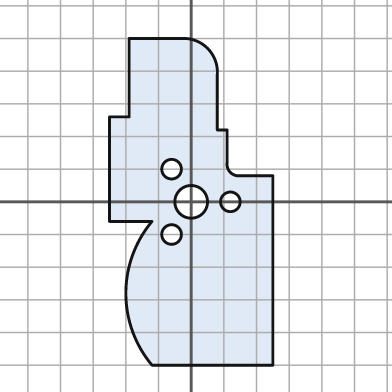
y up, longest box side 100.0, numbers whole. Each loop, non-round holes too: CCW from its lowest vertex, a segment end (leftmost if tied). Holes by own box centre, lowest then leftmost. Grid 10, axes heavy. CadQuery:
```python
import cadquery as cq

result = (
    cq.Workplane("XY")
    .moveTo(-12.0, -50.0)
    .lineTo(25.0, -50.0)
    .lineTo(25.0, 8.0)
    .lineTo(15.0, 8.0)
    .threePointArc((12.0, 9.0), (11.0, 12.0))
    .lineTo(11.0, 22.0)
    .lineTo(8.0, 22.0)
    .lineTo(8.0, 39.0)
    .threePointArc((5.0, 47.0), (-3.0, 50.0))
    .lineTo(-19.0, 50.0)
    .lineTo(-19.0, 26.0)
    .lineTo(-25.0, 26.0)
    .lineTo(-25.0, -6.0)
    .lineTo(-12.0, -6.0)
    .threePointArc((-20.0, -28.0), (-12.0, -50.0))
    .close()
    .moveTo(-6.0, -10.0)
    .circle(3.0)
    .moveTo(0.0, 0.0)
    .circle(5.0)
    .moveTo(12.0, 0.0)
    .circle(3.0)
    .moveTo(-6.0, 10.0)
    .circle(3.0)
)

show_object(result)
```